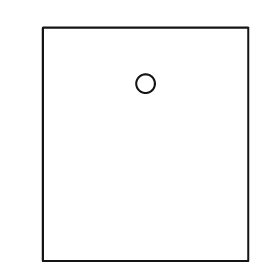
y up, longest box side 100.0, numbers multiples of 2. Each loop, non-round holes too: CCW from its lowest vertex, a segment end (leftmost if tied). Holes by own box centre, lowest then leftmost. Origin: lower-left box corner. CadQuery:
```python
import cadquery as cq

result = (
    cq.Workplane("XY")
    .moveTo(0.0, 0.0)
    .lineTo(88.0, 0.0)
    .lineTo(88.0, 100.0)
    .lineTo(0.0, 100.0)
    .close()
    .moveTo(44.0, 76.0)
    .circle(4.0)
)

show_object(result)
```